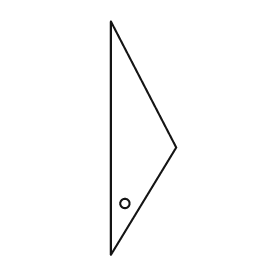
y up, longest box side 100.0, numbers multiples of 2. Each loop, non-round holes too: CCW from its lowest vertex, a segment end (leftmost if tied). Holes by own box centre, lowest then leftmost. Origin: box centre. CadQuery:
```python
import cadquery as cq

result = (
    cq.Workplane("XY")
    .moveTo(-14.0, -50.0)
    .lineTo(14.0, -4.0)
    .lineTo(-14.0, 50.0)
    .close()
    .moveTo(-8.0, -28.0)
    .circle(2.0)
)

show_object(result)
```